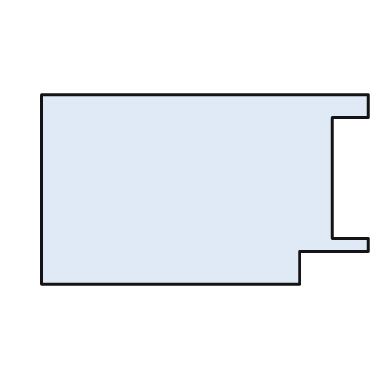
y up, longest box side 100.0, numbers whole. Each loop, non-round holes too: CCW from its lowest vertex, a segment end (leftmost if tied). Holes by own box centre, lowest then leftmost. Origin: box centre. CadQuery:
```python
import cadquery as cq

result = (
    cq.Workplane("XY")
    .moveTo(-50.0, -29.0)
    .lineTo(29.0, -29.0)
    .lineTo(29.0, -19.0)
    .lineTo(50.0, -19.0)
    .lineTo(50.0, -15.0)
    .lineTo(39.0, -15.0)
    .lineTo(39.0, 22.0)
    .lineTo(50.0, 22.0)
    .lineTo(50.0, 29.0)
    .lineTo(-50.0, 29.0)
    .close()
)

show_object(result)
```